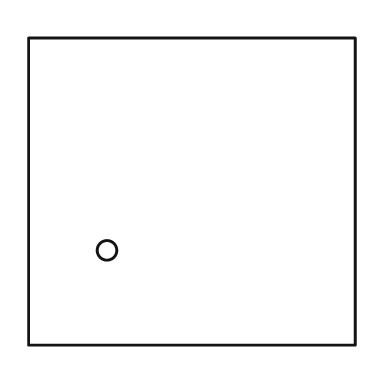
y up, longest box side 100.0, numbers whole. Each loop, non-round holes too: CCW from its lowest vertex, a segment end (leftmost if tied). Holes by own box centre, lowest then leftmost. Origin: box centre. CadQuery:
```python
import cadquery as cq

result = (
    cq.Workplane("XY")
    .moveTo(-50.0, -47.0)
    .lineTo(50.0, -47.0)
    .lineTo(50.0, 47.0)
    .lineTo(-50.0, 47.0)
    .close()
    .moveTo(-26.0, -18.0)
    .circle(3.0)
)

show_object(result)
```